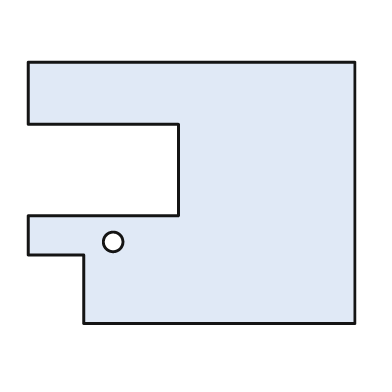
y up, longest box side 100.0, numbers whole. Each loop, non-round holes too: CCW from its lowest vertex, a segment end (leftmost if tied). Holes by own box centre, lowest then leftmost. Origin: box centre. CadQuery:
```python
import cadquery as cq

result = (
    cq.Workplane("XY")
    .moveTo(-33.0, -40.0)
    .lineTo(50.0, -40.0)
    .lineTo(50.0, 40.0)
    .lineTo(-50.0, 40.0)
    .lineTo(-50.0, 21.0)
    .lineTo(-4.0, 21.0)
    .lineTo(-4.0, -7.0)
    .lineTo(-50.0, -7.0)
    .lineTo(-50.0, -19.0)
    .lineTo(-33.0, -19.0)
    .close()
    .moveTo(-24.0, -15.0)
    .circle(3.0)
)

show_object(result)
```